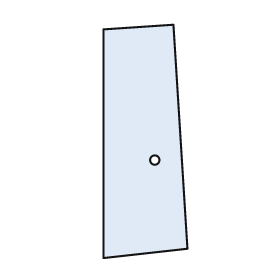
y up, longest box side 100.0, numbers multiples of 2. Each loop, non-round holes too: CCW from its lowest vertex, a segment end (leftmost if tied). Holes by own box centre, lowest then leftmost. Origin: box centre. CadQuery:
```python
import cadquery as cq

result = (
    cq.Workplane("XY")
    .moveTo(-18.0, -50.0)
    .lineTo(18.0, -46.0)
    .lineTo(12.0, 50.0)
    .lineTo(-18.0, 48.0)
    .close()
    .moveTo(4.0, -8.0)
    .circle(2.0)
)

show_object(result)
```